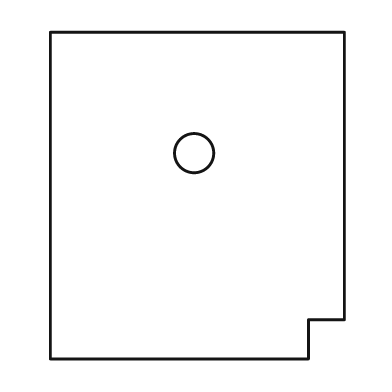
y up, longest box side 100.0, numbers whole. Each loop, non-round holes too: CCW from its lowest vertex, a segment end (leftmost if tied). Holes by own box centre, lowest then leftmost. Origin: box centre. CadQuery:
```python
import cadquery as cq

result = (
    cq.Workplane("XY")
    .moveTo(-45.0, -50.0)
    .lineTo(34.0, -50.0)
    .lineTo(34.0, -38.0)
    .lineTo(45.0, -38.0)
    .lineTo(45.0, 50.0)
    .lineTo(-45.0, 50.0)
    .close()
    .moveTo(-1.0, 13.0)
    .circle(6.0)
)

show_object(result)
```